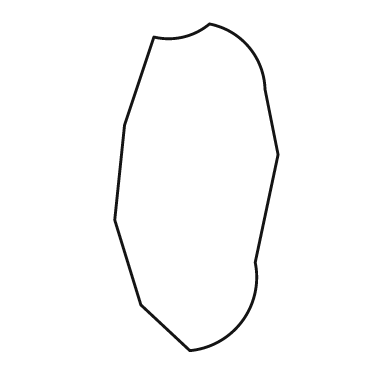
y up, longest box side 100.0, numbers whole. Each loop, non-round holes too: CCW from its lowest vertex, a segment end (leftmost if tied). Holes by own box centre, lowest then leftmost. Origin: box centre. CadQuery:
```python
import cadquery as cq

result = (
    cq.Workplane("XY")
    .moveTo(-2.0, -50.0)
    .threePointArc((14.0, -41.0), (18.0, -23.0))
    .lineTo(25.0, 10.0)
    .lineTo(21.0, 30.0)
    .threePointArc((16.0, 43.0), (4.0, 50.0))
    .threePointArc((-4.0, 46.0), (-13.0, 46.0))
    .lineTo(-22.0, 19.0)
    .lineTo(-25.0, -10.0)
    .lineTo(-17.0, -36.0)
    .close()
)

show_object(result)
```